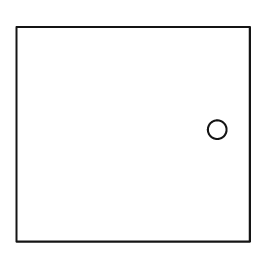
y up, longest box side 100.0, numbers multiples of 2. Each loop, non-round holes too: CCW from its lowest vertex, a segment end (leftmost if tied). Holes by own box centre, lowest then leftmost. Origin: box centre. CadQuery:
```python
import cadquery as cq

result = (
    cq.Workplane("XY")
    .moveTo(-50.0, -46.0)
    .lineTo(50.0, -46.0)
    .lineTo(50.0, 46.0)
    .lineTo(-50.0, 46.0)
    .close()
    .moveTo(36.0, 2.0)
    .circle(4.0)
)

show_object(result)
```